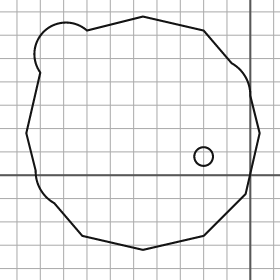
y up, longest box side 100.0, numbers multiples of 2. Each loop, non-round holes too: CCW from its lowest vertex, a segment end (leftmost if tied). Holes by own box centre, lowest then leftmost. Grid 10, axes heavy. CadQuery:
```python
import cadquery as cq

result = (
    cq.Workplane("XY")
    .moveTo(-46.0, -32.0)
    .lineTo(-20.0, -26.0)
    .lineTo(-2.0, -8.0)
    .lineTo(4.0, 18.0)
    .lineTo(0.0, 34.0)
    .threePointArc((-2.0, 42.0), (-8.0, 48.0))
    .lineTo(-20.0, 62.0)
    .lineTo(-46.0, 68.0)
    .lineTo(-70.0, 62.0)
    .threePointArc((-88.0, 62.0), (-90.0, 44.0))
    .lineTo(-96.0, 18.0)
    .lineTo(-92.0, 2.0)
    .threePointArc((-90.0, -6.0), (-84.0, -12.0))
    .lineTo(-72.0, -26.0)
    .close()
    .moveTo(-20.0, 8.0)
    .circle(4.0)
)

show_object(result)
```